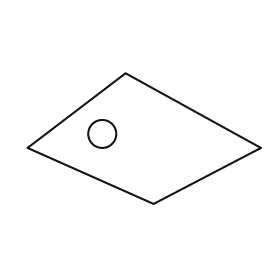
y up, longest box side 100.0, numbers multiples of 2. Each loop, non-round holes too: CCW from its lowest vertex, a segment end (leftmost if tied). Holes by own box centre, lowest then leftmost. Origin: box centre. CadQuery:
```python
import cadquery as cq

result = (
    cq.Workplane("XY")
    .moveTo(4.0, -28.0)
    .lineTo(50.0, -4.0)
    .lineTo(-8.0, 28.0)
    .lineTo(-50.0, -4.0)
    .close()
    .moveTo(-18.0, 2.0)
    .circle(6.0)
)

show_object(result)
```